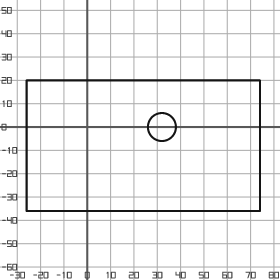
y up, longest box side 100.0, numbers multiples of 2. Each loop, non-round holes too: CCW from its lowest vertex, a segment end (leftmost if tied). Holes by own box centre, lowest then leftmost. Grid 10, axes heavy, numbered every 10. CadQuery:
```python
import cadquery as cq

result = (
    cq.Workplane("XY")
    .moveTo(-26.0, -36.0)
    .lineTo(74.0, -36.0)
    .lineTo(74.0, 20.0)
    .lineTo(-26.0, 20.0)
    .close()
    .moveTo(32.0, 0.0)
    .circle(6.0)
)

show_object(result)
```